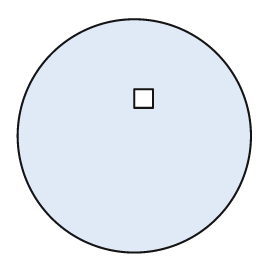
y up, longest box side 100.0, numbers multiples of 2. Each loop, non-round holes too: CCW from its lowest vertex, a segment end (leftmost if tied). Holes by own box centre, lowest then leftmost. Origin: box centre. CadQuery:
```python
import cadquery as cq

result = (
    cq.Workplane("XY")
    .moveTo(0.0, 0.0)
    .circle(50.0)
    .moveTo(0.0, 12.0)
    .lineTo(8.0, 12.0)
    .lineTo(8.0, 20.0)
    .lineTo(0.0, 20.0)
    .close()
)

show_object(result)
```